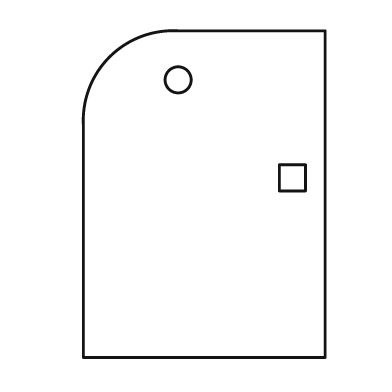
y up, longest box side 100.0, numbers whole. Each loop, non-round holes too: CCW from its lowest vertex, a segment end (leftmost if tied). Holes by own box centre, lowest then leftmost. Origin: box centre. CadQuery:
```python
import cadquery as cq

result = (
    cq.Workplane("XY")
    .moveTo(-37.0, -50.0)
    .lineTo(37.0, -50.0)
    .lineTo(37.0, 50.0)
    .lineTo(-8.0, 50.0)
    .threePointArc((-29.0, 42.0), (-37.0, 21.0))
    .close()
    .moveTo(23.0, 1.0)
    .lineTo(31.0, 1.0)
    .lineTo(31.0, 9.0)
    .lineTo(23.0, 9.0)
    .close()
    .moveTo(-8.0, 35.0)
    .circle(4.0)
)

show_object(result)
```